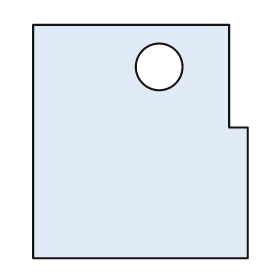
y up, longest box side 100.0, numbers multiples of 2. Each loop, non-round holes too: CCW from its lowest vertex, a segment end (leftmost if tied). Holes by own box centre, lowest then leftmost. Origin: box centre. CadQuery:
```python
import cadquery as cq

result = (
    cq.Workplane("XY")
    .moveTo(-46.0, -50.0)
    .lineTo(46.0, -50.0)
    .lineTo(46.0, 6.0)
    .lineTo(38.0, 6.0)
    .lineTo(38.0, 50.0)
    .lineTo(-46.0, 50.0)
    .close()
    .moveTo(8.0, 32.0)
    .circle(10.0)
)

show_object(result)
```